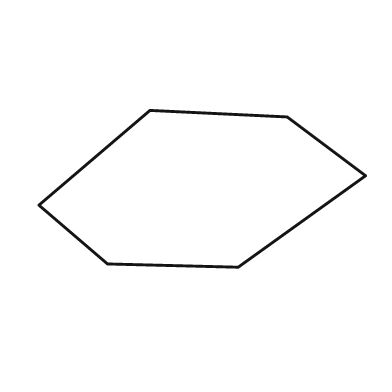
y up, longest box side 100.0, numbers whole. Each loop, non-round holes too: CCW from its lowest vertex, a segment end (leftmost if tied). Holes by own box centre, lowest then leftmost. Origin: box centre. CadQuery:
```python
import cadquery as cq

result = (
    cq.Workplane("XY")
    .moveTo(11.0, -24.0)
    .lineTo(50.0, 4.0)
    .lineTo(26.0, 22.0)
    .lineTo(-16.0, 24.0)
    .lineTo(-50.0, -5.0)
    .lineTo(-29.0, -23.0)
    .close()
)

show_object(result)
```